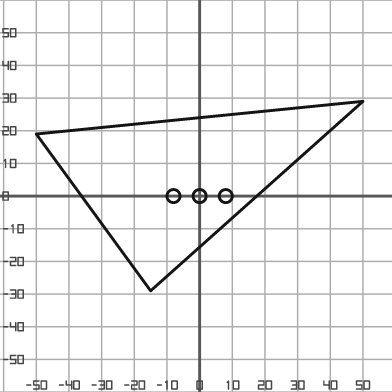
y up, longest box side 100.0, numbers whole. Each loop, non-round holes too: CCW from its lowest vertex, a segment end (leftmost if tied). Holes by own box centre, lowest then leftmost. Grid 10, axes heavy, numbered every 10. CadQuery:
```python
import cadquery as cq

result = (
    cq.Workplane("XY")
    .moveTo(-15.0, -29.0)
    .lineTo(50.0, 29.0)
    .lineTo(-50.0, 19.0)
    .close()
    .moveTo(-8.0, 0.0)
    .circle(2.0)
    .moveTo(0.0, 0.0)
    .circle(2.0)
    .moveTo(8.0, 0.0)
    .circle(2.0)
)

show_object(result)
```